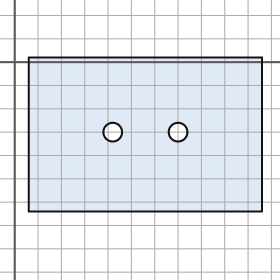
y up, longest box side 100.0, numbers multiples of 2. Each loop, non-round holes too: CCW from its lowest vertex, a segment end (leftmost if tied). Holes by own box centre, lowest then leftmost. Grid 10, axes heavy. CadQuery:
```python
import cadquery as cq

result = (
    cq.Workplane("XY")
    .moveTo(6.0, -64.0)
    .lineTo(106.0, -64.0)
    .lineTo(106.0, 2.0)
    .lineTo(6.0, 2.0)
    .close()
    .moveTo(42.0, -30.0)
    .circle(4.0)
    .moveTo(70.0, -30.0)
    .circle(4.0)
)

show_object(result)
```